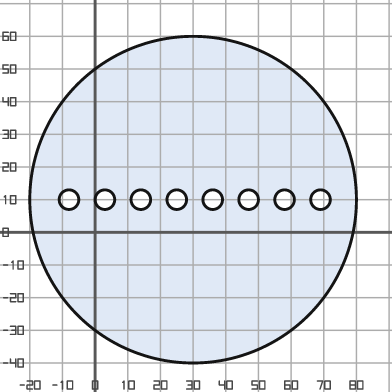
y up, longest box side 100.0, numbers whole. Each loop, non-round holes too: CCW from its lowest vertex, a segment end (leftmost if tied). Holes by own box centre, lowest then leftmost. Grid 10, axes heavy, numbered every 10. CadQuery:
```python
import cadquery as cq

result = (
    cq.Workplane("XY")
    .moveTo(30.0, 10.0)
    .circle(50.0)
    .moveTo(-8.0, 10.0)
    .circle(3.0)
    .moveTo(3.0, 10.0)
    .circle(3.0)
    .moveTo(14.0, 10.0)
    .circle(3.0)
    .moveTo(25.0, 10.0)
    .circle(3.0)
    .moveTo(36.0, 10.0)
    .circle(3.0)
    .moveTo(47.0, 10.0)
    .circle(3.0)
    .moveTo(58.0, 10.0)
    .circle(3.0)
    .moveTo(69.0, 10.0)
    .circle(3.0)
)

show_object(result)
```